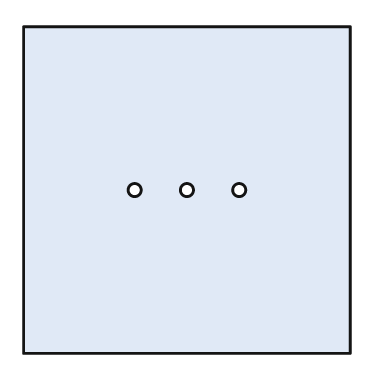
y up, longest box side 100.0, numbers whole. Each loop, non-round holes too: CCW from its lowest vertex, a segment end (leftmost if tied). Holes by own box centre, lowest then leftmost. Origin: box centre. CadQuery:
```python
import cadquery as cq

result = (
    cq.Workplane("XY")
    .moveTo(-50.0, -50.0)
    .lineTo(50.0, -50.0)
    .lineTo(50.0, 50.0)
    .lineTo(-50.0, 50.0)
    .close()
    .moveTo(-16.0, 0.0)
    .circle(2.0)
    .moveTo(0.0, 0.0)
    .circle(2.0)
    .moveTo(16.0, 0.0)
    .circle(2.0)
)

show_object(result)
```